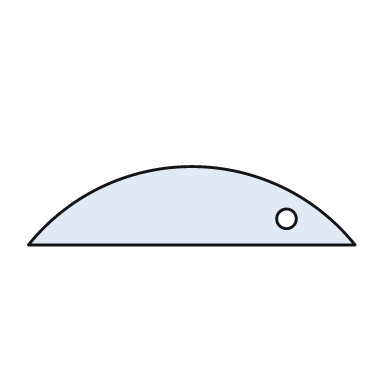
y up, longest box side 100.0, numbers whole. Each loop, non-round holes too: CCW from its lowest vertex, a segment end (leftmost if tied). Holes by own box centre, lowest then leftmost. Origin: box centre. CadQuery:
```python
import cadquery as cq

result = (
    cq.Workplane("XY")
    .moveTo(-50.0, -12.0)
    .lineTo(50.0, -12.0)
    .threePointArc((0.0, 12.0), (-50.0, -12.0))
    .close()
    .moveTo(29.0, -4.0)
    .circle(3.0)
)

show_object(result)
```